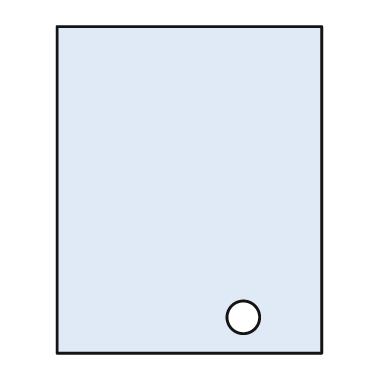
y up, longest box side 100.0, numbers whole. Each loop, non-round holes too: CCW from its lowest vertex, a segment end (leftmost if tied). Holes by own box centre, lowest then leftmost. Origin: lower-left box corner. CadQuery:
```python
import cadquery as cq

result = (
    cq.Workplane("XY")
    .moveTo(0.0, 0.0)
    .lineTo(81.0, 0.0)
    .lineTo(81.0, 100.0)
    .lineTo(0.0, 100.0)
    .close()
    .moveTo(57.0, 11.0)
    .circle(5.0)
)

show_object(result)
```